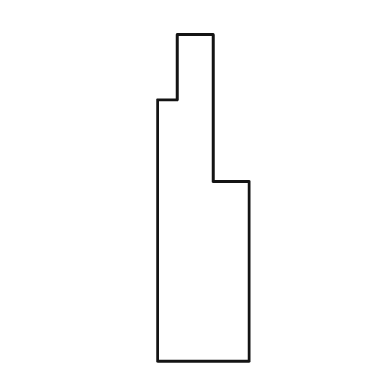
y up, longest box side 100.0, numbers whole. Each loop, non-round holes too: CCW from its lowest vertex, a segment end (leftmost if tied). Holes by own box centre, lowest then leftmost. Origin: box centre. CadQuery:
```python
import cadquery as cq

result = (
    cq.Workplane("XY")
    .moveTo(-14.0, -50.0)
    .lineTo(14.0, -50.0)
    .lineTo(14.0, 5.0)
    .lineTo(3.0, 5.0)
    .lineTo(3.0, 50.0)
    .lineTo(-8.0, 50.0)
    .lineTo(-8.0, 30.0)
    .lineTo(-14.0, 30.0)
    .close()
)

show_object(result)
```